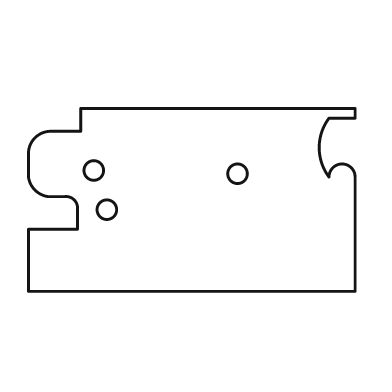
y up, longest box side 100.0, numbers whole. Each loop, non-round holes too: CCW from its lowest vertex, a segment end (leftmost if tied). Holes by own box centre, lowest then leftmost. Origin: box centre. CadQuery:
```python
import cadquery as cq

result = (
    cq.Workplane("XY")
    .moveTo(-50.0, -28.0)
    .lineTo(50.0, -28.0)
    .lineTo(50.0, 7.0)
    .threePointArc((46.0, 11.0), (42.0, 7.0))
    .threePointArc((39.0, 16.0), (42.0, 25.0))
    .lineTo(50.0, 25.0)
    .lineTo(50.0, 28.0)
    .lineTo(-34.0, 28.0)
    .lineTo(-34.0, 21.0)
    .lineTo(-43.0, 21.0)
    .threePointArc((-48.0, 19.0), (-50.0, 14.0))
    .lineTo(-50.0, 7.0)
    .threePointArc((-48.0, 3.0), (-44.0, 1.0))
    .lineTo(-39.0, 1.0)
    .threePointArc((-36.0, 0.0), (-35.0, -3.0))
    .lineTo(-35.0, -9.0)
    .lineTo(-50.0, -9.0)
    .close()
    .moveTo(-26.0, -3.0)
    .circle(3.0)
    .moveTo(14.0, 8.0)
    .circle(3.0)
    .moveTo(-30.0, 9.0)
    .circle(3.0)
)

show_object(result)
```